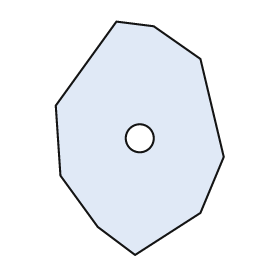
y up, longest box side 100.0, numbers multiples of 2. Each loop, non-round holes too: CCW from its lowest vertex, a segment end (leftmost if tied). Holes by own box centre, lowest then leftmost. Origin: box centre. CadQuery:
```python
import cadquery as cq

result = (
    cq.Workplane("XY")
    .moveTo(-2.0, -50.0)
    .lineTo(26.0, -32.0)
    .lineTo(36.0, -8.0)
    .lineTo(26.0, 34.0)
    .lineTo(6.0, 48.0)
    .lineTo(-10.0, 50.0)
    .lineTo(-36.0, 14.0)
    .lineTo(-34.0, -16.0)
    .lineTo(-18.0, -38.0)
    .close()
    .moveTo(0.0, 0.0)
    .circle(6.0)
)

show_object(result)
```